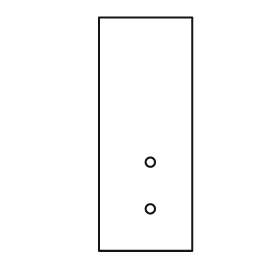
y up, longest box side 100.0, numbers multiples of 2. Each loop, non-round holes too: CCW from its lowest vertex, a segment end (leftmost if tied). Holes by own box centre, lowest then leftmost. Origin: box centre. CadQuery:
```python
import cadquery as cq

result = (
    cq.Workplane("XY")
    .moveTo(-20.0, -50.0)
    .lineTo(20.0, -50.0)
    .lineTo(20.0, 50.0)
    .lineTo(-20.0, 50.0)
    .close()
    .moveTo(2.0, -32.0)
    .circle(2.0)
    .moveTo(2.0, -12.0)
    .circle(2.0)
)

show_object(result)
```